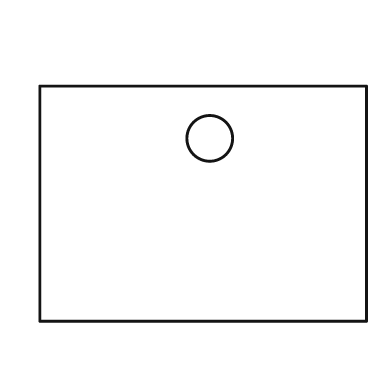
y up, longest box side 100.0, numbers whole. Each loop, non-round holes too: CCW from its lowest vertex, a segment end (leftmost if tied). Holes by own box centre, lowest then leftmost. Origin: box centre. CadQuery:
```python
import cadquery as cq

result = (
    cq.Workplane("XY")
    .moveTo(-50.0, -36.0)
    .lineTo(50.0, -36.0)
    .lineTo(50.0, 36.0)
    .lineTo(-50.0, 36.0)
    .close()
    .moveTo(2.0, 20.0)
    .circle(7.0)
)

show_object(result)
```